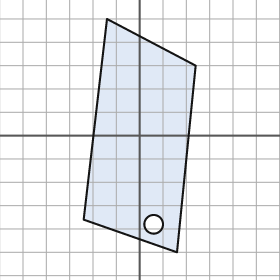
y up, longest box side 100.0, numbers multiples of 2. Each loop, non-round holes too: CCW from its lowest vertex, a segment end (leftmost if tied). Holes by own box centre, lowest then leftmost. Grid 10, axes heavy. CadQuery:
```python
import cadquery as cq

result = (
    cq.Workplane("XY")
    .moveTo(16.0, -50.0)
    .lineTo(24.0, 30.0)
    .lineTo(-14.0, 50.0)
    .lineTo(-24.0, -36.0)
    .close()
    .moveTo(6.0, -38.0)
    .circle(4.0)
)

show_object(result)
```